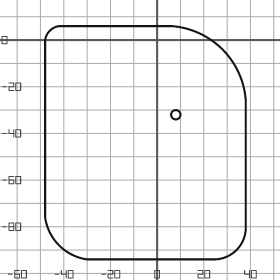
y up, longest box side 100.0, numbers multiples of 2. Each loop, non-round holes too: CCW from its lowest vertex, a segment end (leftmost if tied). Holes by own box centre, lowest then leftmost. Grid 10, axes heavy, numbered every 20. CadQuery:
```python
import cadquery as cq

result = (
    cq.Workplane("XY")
    .moveTo(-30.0, -94.0)
    .lineTo(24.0, -94.0)
    .threePointArc((34.0, -90.0), (38.0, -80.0))
    .lineTo(38.0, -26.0)
    .threePointArc((28.0, -4.0), (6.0, 6.0))
    .lineTo(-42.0, 6.0)
    .threePointArc((-46.0, 4.0), (-48.0, 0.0))
    .lineTo(-48.0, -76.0)
    .threePointArc((-42.0, -88.0), (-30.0, -94.0))
    .close()
    .moveTo(8.0, -32.0)
    .circle(2.0)
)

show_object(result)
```